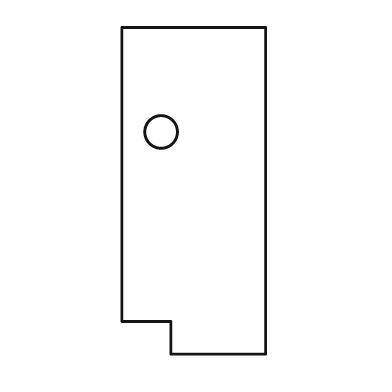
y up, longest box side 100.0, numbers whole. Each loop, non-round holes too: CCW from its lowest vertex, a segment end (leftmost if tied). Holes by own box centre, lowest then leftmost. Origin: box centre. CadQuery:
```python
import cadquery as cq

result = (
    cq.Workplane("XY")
    .moveTo(-7.0, -50.0)
    .lineTo(22.0, -50.0)
    .lineTo(22.0, 50.0)
    .lineTo(-22.0, 50.0)
    .lineTo(-22.0, -40.0)
    .lineTo(-7.0, -40.0)
    .close()
    .moveTo(-10.0, 18.0)
    .circle(5.0)
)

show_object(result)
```